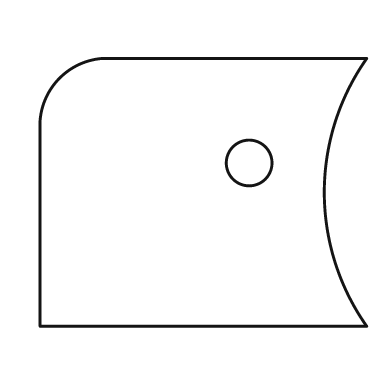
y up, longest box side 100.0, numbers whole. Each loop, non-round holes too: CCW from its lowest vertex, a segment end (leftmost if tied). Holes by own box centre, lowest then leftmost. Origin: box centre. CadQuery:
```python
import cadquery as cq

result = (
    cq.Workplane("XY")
    .moveTo(-50.0, -41.0)
    .lineTo(50.0, -41.0)
    .threePointArc((37.0, 0.0), (50.0, 41.0))
    .lineTo(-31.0, 41.0)
    .threePointArc((-44.0, 35.0), (-50.0, 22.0))
    .close()
    .moveTo(14.0, 9.0)
    .circle(7.0)
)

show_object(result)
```